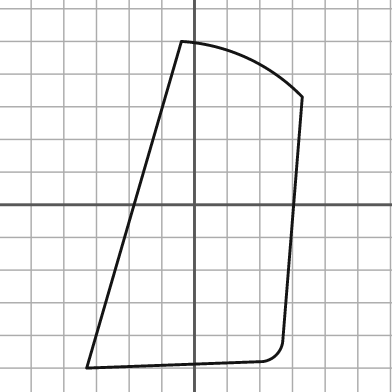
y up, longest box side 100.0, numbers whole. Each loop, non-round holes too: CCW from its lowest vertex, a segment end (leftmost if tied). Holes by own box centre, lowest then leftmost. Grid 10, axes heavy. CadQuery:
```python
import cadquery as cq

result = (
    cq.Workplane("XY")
    .moveTo(-33.0, -50.0)
    .lineTo(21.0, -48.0)
    .threePointArc((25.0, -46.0), (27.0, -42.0))
    .lineTo(33.0, 33.0)
    .threePointArc((16.0, 45.0), (-4.0, 50.0))
    .close()
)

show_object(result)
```